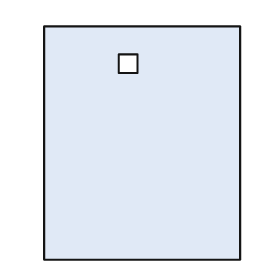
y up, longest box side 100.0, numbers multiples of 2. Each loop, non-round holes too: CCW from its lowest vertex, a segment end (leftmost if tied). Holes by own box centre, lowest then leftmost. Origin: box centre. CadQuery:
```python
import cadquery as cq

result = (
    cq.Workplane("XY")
    .moveTo(-42.0, -50.0)
    .lineTo(42.0, -50.0)
    .lineTo(42.0, 50.0)
    .lineTo(-42.0, 50.0)
    .close()
    .moveTo(-10.0, 30.0)
    .lineTo(-2.0, 30.0)
    .lineTo(-2.0, 38.0)
    .lineTo(-10.0, 38.0)
    .close()
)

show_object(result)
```